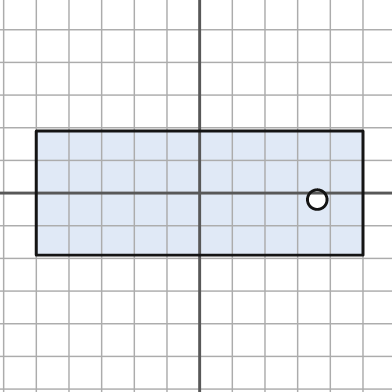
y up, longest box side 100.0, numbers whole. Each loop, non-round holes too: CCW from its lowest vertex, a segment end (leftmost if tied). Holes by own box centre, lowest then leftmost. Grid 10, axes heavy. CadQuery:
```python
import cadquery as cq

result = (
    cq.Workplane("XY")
    .moveTo(-50.0, -19.0)
    .lineTo(50.0, -19.0)
    .lineTo(50.0, 19.0)
    .lineTo(-50.0, 19.0)
    .close()
    .moveTo(36.0, -2.0)
    .circle(3.0)
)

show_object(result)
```